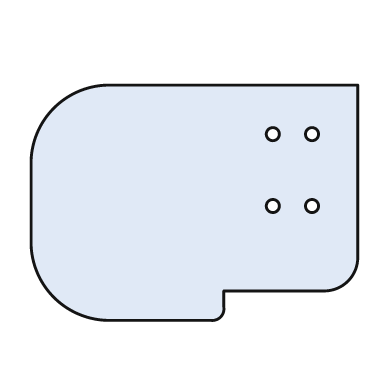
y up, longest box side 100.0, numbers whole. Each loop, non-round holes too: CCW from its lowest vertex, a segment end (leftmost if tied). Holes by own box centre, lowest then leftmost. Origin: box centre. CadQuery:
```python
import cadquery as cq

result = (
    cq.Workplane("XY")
    .moveTo(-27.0, -36.0)
    .lineTo(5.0, -36.0)
    .threePointArc((8.0, -35.0), (9.0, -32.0))
    .lineTo(9.0, -27.0)
    .lineTo(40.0, -27.0)
    .threePointArc((47.0, -24.0), (50.0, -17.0))
    .lineTo(50.0, 36.0)
    .lineTo(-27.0, 36.0)
    .threePointArc((-43.0, 29.0), (-50.0, 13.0))
    .lineTo(-50.0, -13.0)
    .threePointArc((-43.0, -29.0), (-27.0, -36.0))
    .close()
    .moveTo(24.0, -1.0)
    .circle(2.0)
    .moveTo(36.0, -1.0)
    .circle(2.0)
    .moveTo(24.0, 21.0)
    .circle(2.0)
    .moveTo(36.0, 21.0)
    .circle(2.0)
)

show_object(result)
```